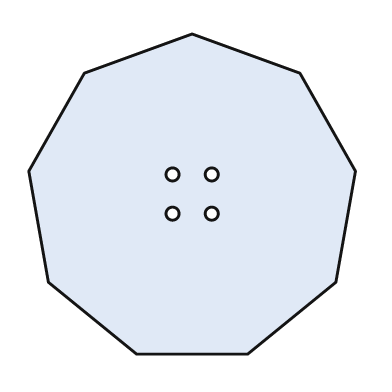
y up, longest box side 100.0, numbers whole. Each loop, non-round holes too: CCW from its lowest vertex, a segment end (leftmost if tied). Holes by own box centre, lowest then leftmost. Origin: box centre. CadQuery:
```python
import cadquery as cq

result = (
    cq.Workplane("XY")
    .moveTo(-17.0, -49.0)
    .lineTo(17.0, -49.0)
    .lineTo(44.0, -27.0)
    .lineTo(50.0, 7.0)
    .lineTo(33.0, 37.0)
    .lineTo(0.0, 49.0)
    .lineTo(-33.0, 37.0)
    .lineTo(-50.0, 7.0)
    .lineTo(-44.0, -27.0)
    .close()
    .moveTo(-6.0, -6.0)
    .circle(2.0)
    .moveTo(6.0, -6.0)
    .circle(2.0)
    .moveTo(-6.0, 6.0)
    .circle(2.0)
    .moveTo(6.0, 6.0)
    .circle(2.0)
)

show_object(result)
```